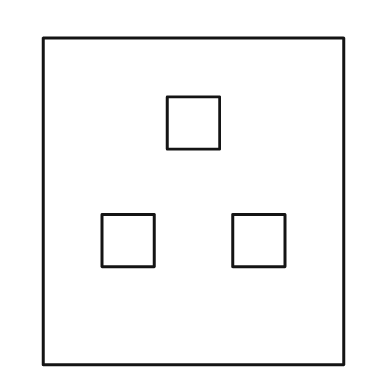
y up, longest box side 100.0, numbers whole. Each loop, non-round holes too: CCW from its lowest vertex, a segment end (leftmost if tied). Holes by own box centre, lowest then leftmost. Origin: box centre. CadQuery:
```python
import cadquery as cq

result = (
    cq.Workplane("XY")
    .moveTo(-46.0, -50.0)
    .lineTo(46.0, -50.0)
    .lineTo(46.0, 50.0)
    .lineTo(-46.0, 50.0)
    .close()
    .moveTo(-28.0, -20.0)
    .lineTo(-12.0, -20.0)
    .lineTo(-12.0, -4.0)
    .lineTo(-28.0, -4.0)
    .close()
    .moveTo(12.0, -20.0)
    .lineTo(28.0, -20.0)
    .lineTo(28.0, -4.0)
    .lineTo(12.0, -4.0)
    .close()
    .moveTo(-8.0, 16.0)
    .lineTo(8.0, 16.0)
    .lineTo(8.0, 32.0)
    .lineTo(-8.0, 32.0)
    .close()
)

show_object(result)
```